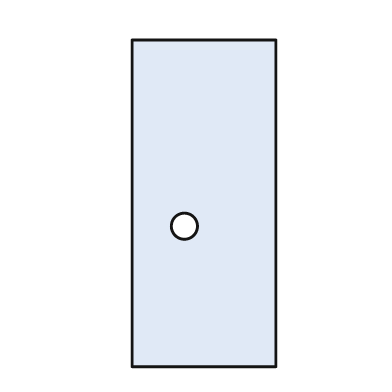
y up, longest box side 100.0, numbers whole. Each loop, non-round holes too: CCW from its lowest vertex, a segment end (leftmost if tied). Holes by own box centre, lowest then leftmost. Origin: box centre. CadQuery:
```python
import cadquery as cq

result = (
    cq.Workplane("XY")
    .moveTo(-22.0, -50.0)
    .lineTo(22.0, -50.0)
    .lineTo(22.0, 50.0)
    .lineTo(-22.0, 50.0)
    .close()
    .moveTo(-6.0, -7.0)
    .circle(4.0)
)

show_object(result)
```